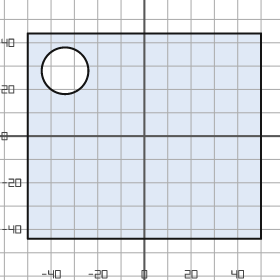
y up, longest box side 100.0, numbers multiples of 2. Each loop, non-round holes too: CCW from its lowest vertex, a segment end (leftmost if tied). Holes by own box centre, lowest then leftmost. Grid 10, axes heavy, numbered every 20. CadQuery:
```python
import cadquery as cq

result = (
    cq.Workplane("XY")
    .moveTo(-50.0, -44.0)
    .lineTo(50.0, -44.0)
    .lineTo(50.0, 44.0)
    .lineTo(-50.0, 44.0)
    .close()
    .moveTo(-34.0, 28.0)
    .circle(10.0)
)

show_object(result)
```